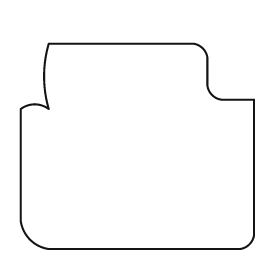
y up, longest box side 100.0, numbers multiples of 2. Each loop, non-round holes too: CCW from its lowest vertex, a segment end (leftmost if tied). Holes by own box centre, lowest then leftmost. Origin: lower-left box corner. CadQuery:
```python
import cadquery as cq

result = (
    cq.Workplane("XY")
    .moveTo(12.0, 0.0)
    .lineTo(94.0, 0.0)
    .threePointArc((98.0, 2.0), (100.0, 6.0))
    .lineTo(100.0, 64.0)
    .lineTo(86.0, 64.0)
    .threePointArc((82.0, 66.0), (80.0, 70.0))
    .lineTo(80.0, 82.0)
    .threePointArc((78.0, 86.0), (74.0, 88.0))
    .lineTo(12.0, 88.0)
    .threePointArc((10.0, 74.0), (12.0, 60.0))
    .threePointArc((6.0, 62.0), (0.0, 60.0))
    .lineTo(0.0, 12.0)
    .threePointArc((4.0, 4.0), (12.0, 0.0))
    .close()
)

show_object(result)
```